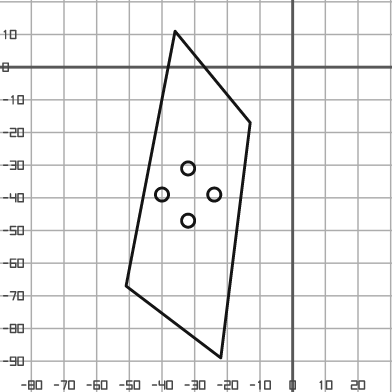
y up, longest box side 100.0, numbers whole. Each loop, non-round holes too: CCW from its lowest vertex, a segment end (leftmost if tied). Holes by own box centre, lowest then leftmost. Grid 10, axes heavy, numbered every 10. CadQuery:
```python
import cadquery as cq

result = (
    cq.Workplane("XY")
    .moveTo(-22.0, -89.0)
    .lineTo(-13.0, -17.0)
    .lineTo(-36.0, 11.0)
    .lineTo(-51.0, -67.0)
    .close()
    .moveTo(-32.0, -47.0)
    .circle(2.0)
    .moveTo(-40.0, -39.0)
    .circle(2.0)
    .moveTo(-24.0, -39.0)
    .circle(2.0)
    .moveTo(-32.0, -31.0)
    .circle(2.0)
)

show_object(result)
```